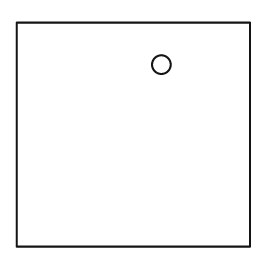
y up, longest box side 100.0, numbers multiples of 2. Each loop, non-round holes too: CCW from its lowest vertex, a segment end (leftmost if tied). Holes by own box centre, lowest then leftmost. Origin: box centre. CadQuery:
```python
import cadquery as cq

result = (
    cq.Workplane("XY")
    .moveTo(-50.0, -48.0)
    .lineTo(50.0, -48.0)
    .lineTo(50.0, 48.0)
    .lineTo(-50.0, 48.0)
    .close()
    .moveTo(12.0, 30.0)
    .circle(4.0)
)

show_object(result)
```